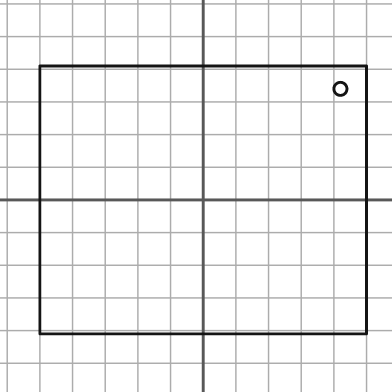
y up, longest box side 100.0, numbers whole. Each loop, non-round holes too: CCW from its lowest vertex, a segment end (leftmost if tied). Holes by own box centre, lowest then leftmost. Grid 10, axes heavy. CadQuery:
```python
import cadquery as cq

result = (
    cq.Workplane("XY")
    .moveTo(-50.0, -41.0)
    .lineTo(50.0, -41.0)
    .lineTo(50.0, 41.0)
    .lineTo(-50.0, 41.0)
    .close()
    .moveTo(42.0, 34.0)
    .circle(2.0)
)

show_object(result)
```